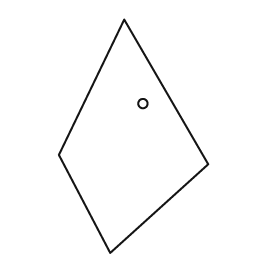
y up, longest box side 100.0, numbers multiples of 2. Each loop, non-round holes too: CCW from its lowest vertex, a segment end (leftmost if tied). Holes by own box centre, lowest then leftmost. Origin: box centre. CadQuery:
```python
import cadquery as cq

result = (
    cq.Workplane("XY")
    .moveTo(-10.0, -50.0)
    .lineTo(32.0, -12.0)
    .lineTo(-4.0, 50.0)
    .lineTo(-32.0, -8.0)
    .close()
    .moveTo(4.0, 14.0)
    .circle(2.0)
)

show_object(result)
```